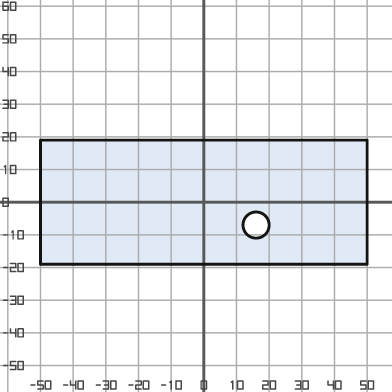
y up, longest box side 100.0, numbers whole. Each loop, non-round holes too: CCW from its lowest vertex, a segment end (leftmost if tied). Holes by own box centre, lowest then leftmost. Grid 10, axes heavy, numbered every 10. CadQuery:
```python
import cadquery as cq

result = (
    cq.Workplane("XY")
    .moveTo(-50.0, -19.0)
    .lineTo(50.0, -19.0)
    .lineTo(50.0, 19.0)
    .lineTo(-50.0, 19.0)
    .close()
    .moveTo(16.0, -7.0)
    .circle(4.0)
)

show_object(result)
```